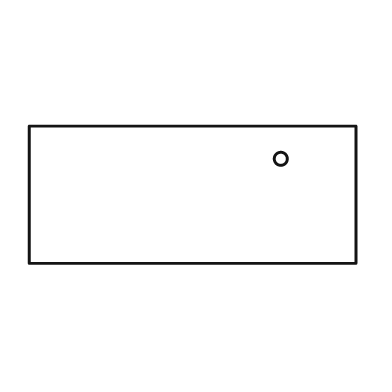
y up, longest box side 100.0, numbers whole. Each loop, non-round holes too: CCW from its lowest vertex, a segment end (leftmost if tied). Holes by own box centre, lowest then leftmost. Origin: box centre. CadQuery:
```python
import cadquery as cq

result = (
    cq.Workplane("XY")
    .moveTo(-50.0, -21.0)
    .lineTo(50.0, -21.0)
    .lineTo(50.0, 21.0)
    .lineTo(-50.0, 21.0)
    .close()
    .moveTo(27.0, 11.0)
    .circle(2.0)
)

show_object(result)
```